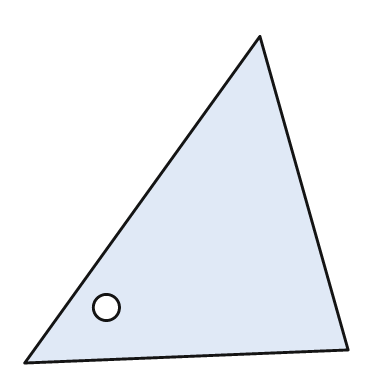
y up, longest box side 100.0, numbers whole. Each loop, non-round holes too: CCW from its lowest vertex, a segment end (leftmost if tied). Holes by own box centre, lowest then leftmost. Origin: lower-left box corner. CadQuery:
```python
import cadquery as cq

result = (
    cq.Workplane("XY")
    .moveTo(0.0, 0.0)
    .lineTo(99.0, 4.0)
    .lineTo(72.0, 100.0)
    .close()
    .moveTo(25.0, 17.0)
    .circle(4.0)
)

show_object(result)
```